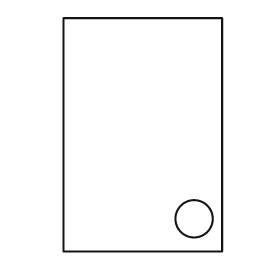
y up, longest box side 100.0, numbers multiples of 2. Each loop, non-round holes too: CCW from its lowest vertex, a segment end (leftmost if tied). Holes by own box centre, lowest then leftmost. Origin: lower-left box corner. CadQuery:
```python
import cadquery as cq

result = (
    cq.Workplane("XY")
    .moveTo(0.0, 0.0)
    .lineTo(68.0, 0.0)
    .lineTo(68.0, 100.0)
    .lineTo(0.0, 100.0)
    .close()
    .moveTo(56.0, 14.0)
    .circle(8.0)
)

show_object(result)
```